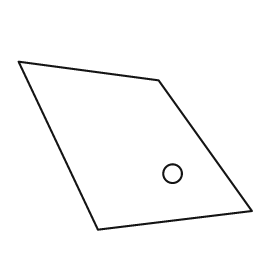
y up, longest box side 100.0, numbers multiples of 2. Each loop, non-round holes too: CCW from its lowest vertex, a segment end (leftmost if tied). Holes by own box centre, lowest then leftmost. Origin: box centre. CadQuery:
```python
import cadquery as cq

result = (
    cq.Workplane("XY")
    .moveTo(-16.0, -36.0)
    .lineTo(50.0, -28.0)
    .lineTo(10.0, 28.0)
    .lineTo(-50.0, 36.0)
    .close()
    .moveTo(16.0, -12.0)
    .circle(4.0)
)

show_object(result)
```